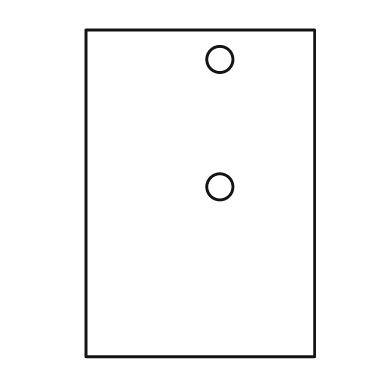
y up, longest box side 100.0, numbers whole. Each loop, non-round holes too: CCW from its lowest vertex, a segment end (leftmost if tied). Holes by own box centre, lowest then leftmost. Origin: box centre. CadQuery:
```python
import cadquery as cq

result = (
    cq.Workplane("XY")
    .moveTo(-35.0, -50.0)
    .lineTo(35.0, -50.0)
    .lineTo(35.0, 50.0)
    .lineTo(-35.0, 50.0)
    .close()
    .moveTo(6.0, 2.0)
    .circle(4.0)
    .moveTo(6.0, 41.0)
    .circle(4.0)
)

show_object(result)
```